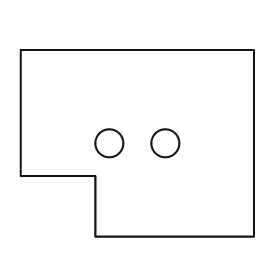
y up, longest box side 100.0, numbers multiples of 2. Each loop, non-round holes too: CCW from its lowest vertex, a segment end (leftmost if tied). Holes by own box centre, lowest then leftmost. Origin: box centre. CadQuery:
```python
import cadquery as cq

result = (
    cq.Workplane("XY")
    .moveTo(-18.0, -40.0)
    .lineTo(50.0, -40.0)
    .lineTo(50.0, 40.0)
    .lineTo(-50.0, 40.0)
    .lineTo(-50.0, -14.0)
    .lineTo(-18.0, -14.0)
    .close()
    .moveTo(-12.0, 0.0)
    .circle(6.0)
    .moveTo(12.0, 0.0)
    .circle(6.0)
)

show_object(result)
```